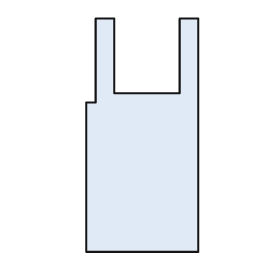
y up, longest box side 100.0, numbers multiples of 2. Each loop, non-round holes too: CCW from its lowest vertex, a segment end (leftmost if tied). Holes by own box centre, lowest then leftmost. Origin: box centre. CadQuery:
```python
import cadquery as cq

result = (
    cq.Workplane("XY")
    .moveTo(-24.0, -50.0)
    .lineTo(24.0, -50.0)
    .lineTo(24.0, 50.0)
    .lineTo(16.0, 50.0)
    .lineTo(16.0, 18.0)
    .lineTo(-12.0, 18.0)
    .lineTo(-12.0, 50.0)
    .lineTo(-20.0, 50.0)
    .lineTo(-20.0, 14.0)
    .lineTo(-24.0, 14.0)
    .close()
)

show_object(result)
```